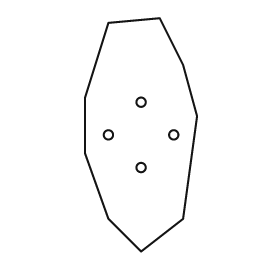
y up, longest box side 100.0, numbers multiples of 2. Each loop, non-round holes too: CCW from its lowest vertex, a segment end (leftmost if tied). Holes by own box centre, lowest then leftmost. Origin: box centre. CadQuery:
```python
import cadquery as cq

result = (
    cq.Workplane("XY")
    .moveTo(0.0, -50.0)
    .lineTo(18.0, -36.0)
    .lineTo(24.0, 8.0)
    .lineTo(18.0, 30.0)
    .lineTo(8.0, 50.0)
    .lineTo(-14.0, 48.0)
    .lineTo(-24.0, 16.0)
    .lineTo(-24.0, -8.0)
    .lineTo(-14.0, -36.0)
    .close()
    .moveTo(0.0, -14.0)
    .circle(2.0)
    .moveTo(-14.0, 0.0)
    .circle(2.0)
    .moveTo(14.0, 0.0)
    .circle(2.0)
    .moveTo(0.0, 14.0)
    .circle(2.0)
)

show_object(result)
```